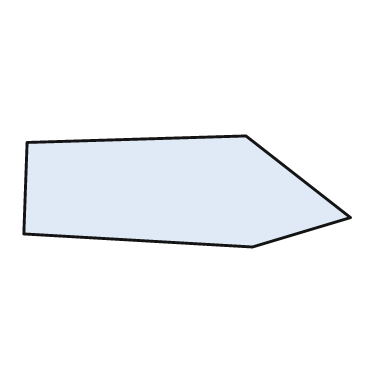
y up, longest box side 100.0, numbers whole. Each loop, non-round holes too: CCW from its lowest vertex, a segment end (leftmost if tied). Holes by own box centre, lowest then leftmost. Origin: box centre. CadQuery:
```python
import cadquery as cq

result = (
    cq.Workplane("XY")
    .moveTo(20.0, -17.0)
    .lineTo(50.0, -8.0)
    .lineTo(18.0, 17.0)
    .lineTo(-49.0, 15.0)
    .lineTo(-50.0, -13.0)
    .close()
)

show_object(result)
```